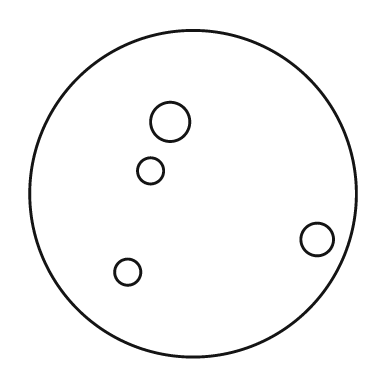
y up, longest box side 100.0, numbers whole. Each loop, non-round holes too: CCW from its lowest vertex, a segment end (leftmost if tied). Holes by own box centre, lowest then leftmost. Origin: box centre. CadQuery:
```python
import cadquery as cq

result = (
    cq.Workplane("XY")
    .moveTo(0.0, 0.0)
    .circle(50.0)
    .moveTo(-20.0, -24.0)
    .circle(4.0)
    .moveTo(38.0, -14.0)
    .circle(5.0)
    .moveTo(-13.0, 7.0)
    .circle(4.0)
    .moveTo(-7.0, 22.0)
    .circle(6.0)
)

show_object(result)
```